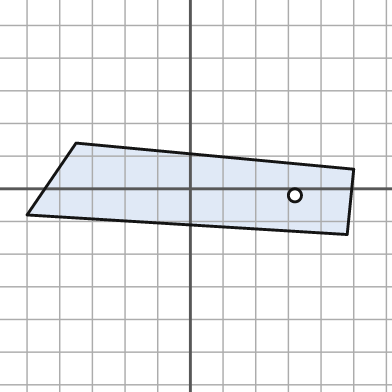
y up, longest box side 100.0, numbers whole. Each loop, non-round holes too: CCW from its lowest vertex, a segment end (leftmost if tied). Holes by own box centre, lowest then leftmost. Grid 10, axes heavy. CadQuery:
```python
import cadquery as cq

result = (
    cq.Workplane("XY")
    .moveTo(48.0, -14.0)
    .lineTo(50.0, 6.0)
    .lineTo(-35.0, 14.0)
    .lineTo(-50.0, -8.0)
    .close()
    .moveTo(32.0, -2.0)
    .circle(2.0)
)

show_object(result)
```